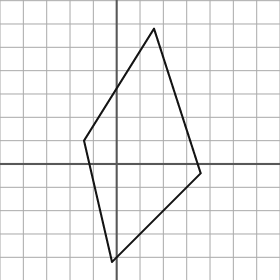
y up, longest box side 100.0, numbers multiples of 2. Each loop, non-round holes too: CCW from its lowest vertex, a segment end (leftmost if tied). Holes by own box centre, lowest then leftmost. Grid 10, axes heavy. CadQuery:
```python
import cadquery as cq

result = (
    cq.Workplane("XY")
    .moveTo(-2.0, -42.0)
    .lineTo(36.0, -4.0)
    .lineTo(16.0, 58.0)
    .lineTo(-14.0, 10.0)
    .close()
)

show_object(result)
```